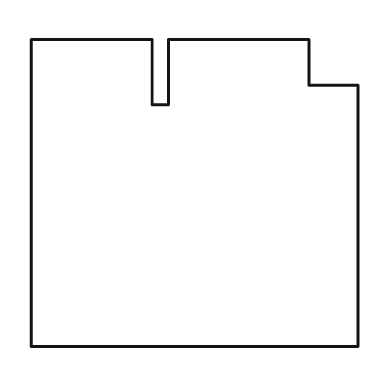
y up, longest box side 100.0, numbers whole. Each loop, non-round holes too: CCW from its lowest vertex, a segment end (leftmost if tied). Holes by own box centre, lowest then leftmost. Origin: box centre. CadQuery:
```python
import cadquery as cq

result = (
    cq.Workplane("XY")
    .moveTo(-50.0, -47.0)
    .lineTo(50.0, -47.0)
    .lineTo(50.0, 33.0)
    .lineTo(35.0, 33.0)
    .lineTo(35.0, 47.0)
    .lineTo(-8.0, 47.0)
    .lineTo(-8.0, 27.0)
    .lineTo(-13.0, 27.0)
    .lineTo(-13.0, 47.0)
    .lineTo(-50.0, 47.0)
    .close()
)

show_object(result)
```